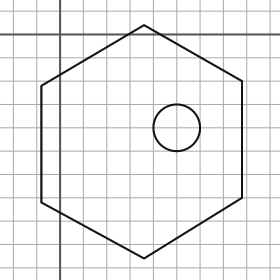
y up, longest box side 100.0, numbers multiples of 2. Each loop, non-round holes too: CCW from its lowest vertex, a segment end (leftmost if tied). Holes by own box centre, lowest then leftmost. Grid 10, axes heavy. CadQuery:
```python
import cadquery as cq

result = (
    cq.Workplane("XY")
    .moveTo(36.0, -96.0)
    .lineTo(78.0, -70.0)
    .lineTo(78.0, -20.0)
    .lineTo(36.0, 4.0)
    .lineTo(-8.0, -22.0)
    .lineTo(-8.0, -72.0)
    .close()
    .moveTo(50.0, -40.0)
    .circle(10.0)
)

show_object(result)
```